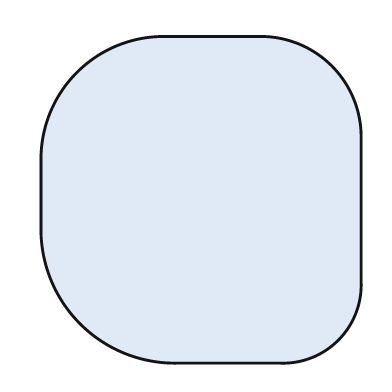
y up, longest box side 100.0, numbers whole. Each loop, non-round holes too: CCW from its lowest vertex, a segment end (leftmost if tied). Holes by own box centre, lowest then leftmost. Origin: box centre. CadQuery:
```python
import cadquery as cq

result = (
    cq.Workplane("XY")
    .moveTo(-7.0, -50.0)
    .lineTo(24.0, -50.0)
    .threePointArc((42.0, -43.0), (49.0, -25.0))
    .lineTo(49.0, 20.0)
    .threePointArc((40.0, 41.0), (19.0, 50.0))
    .lineTo(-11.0, 50.0)
    .threePointArc((-38.0, 39.0), (-49.0, 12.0))
    .lineTo(-49.0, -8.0)
    .threePointArc((-37.0, -38.0), (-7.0, -50.0))
    .close()
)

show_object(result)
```